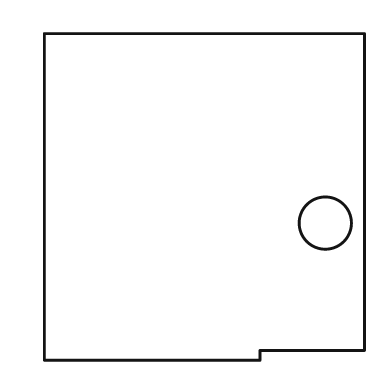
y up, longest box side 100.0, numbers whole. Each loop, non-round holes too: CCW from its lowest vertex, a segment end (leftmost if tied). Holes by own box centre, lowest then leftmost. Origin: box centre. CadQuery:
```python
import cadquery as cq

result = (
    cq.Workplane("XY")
    .moveTo(-49.0, -50.0)
    .lineTo(17.0, -50.0)
    .lineTo(17.0, -47.0)
    .lineTo(49.0, -47.0)
    .lineTo(49.0, 50.0)
    .lineTo(-49.0, 50.0)
    .close()
    .moveTo(37.0, -8.0)
    .circle(8.0)
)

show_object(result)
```